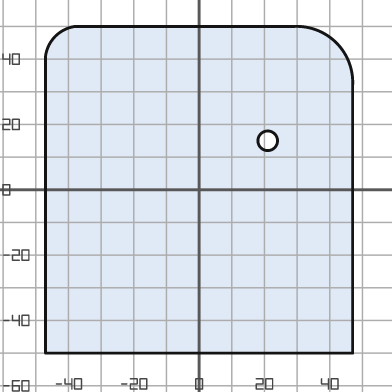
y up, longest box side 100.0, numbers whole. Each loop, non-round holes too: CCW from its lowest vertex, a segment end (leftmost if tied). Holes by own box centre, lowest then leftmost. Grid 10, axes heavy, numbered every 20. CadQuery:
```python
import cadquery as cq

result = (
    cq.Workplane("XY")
    .moveTo(-47.0, -50.0)
    .lineTo(47.0, -50.0)
    .lineTo(47.0, 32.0)
    .threePointArc((42.0, 45.0), (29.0, 50.0))
    .lineTo(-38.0, 50.0)
    .threePointArc((-44.0, 47.0), (-47.0, 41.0))
    .close()
    .moveTo(21.0, 15.0)
    .circle(3.0)
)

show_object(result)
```